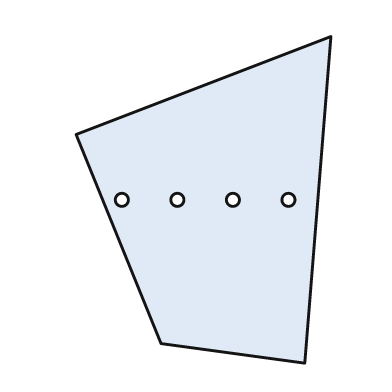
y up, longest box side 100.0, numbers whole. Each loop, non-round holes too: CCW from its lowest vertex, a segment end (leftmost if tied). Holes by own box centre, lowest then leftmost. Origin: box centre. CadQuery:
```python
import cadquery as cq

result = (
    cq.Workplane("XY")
    .moveTo(31.0, -50.0)
    .lineTo(39.0, 50.0)
    .lineTo(-39.0, 20.0)
    .lineTo(-13.0, -44.0)
    .close()
    .moveTo(-25.0, 0.0)
    .circle(2.0)
    .moveTo(-8.0, 0.0)
    .circle(2.0)
    .moveTo(9.0, 0.0)
    .circle(2.0)
    .moveTo(26.0, 0.0)
    .circle(2.0)
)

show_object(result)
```